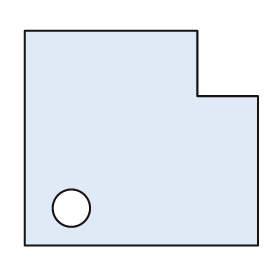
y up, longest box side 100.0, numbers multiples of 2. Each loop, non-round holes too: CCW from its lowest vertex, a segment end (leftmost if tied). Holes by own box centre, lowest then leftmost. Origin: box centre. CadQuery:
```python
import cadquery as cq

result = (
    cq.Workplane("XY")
    .moveTo(-50.0, -46.0)
    .lineTo(50.0, -46.0)
    .lineTo(50.0, 18.0)
    .lineTo(24.0, 18.0)
    .lineTo(24.0, 46.0)
    .lineTo(-50.0, 46.0)
    .close()
    .moveTo(-30.0, -30.0)
    .circle(8.0)
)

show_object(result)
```